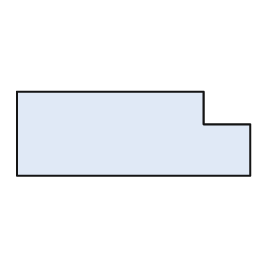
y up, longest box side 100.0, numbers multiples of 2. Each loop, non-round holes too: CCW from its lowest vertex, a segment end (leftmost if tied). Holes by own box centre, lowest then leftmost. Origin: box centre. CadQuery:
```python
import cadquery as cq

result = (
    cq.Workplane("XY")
    .moveTo(-50.0, -18.0)
    .lineTo(50.0, -18.0)
    .lineTo(50.0, 4.0)
    .lineTo(30.0, 4.0)
    .lineTo(30.0, 18.0)
    .lineTo(-50.0, 18.0)
    .close()
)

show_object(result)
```